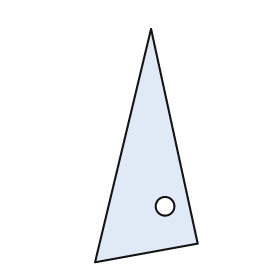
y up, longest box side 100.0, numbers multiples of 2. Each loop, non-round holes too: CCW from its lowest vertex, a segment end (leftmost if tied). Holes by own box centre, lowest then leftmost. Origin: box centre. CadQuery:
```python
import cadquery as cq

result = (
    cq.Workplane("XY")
    .moveTo(-22.0, -50.0)
    .lineTo(22.0, -42.0)
    .lineTo(2.0, 50.0)
    .close()
    .moveTo(8.0, -26.0)
    .circle(4.0)
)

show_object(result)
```